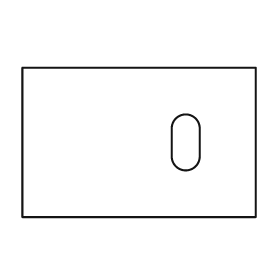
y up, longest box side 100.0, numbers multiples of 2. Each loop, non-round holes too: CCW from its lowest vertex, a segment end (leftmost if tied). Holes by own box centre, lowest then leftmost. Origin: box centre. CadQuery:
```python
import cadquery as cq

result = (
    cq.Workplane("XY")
    .moveTo(-50.0, -32.0)
    .lineTo(50.0, -32.0)
    .lineTo(50.0, 32.0)
    .lineTo(-50.0, 32.0)
    .close()
    .moveTo(14.0, -6.0)
    .threePointArc((20.0, -12.0), (26.0, -6.0))
    .lineTo(26.0, 6.0)
    .threePointArc((20.0, 12.0), (14.0, 6.0))
    .close()
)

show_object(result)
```